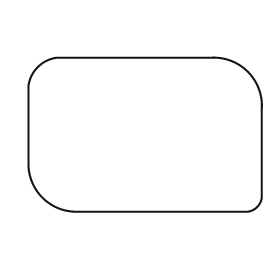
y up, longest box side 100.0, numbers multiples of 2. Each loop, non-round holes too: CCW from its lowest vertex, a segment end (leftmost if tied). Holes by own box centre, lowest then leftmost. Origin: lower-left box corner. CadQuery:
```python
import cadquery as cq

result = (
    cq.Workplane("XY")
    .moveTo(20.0, 0.0)
    .lineTo(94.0, 0.0)
    .threePointArc((98.0, 2.0), (100.0, 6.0))
    .lineTo(100.0, 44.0)
    .threePointArc((94.0, 60.0), (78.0, 66.0))
    .lineTo(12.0, 66.0)
    .threePointArc((4.0, 62.0), (0.0, 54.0))
    .lineTo(0.0, 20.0)
    .threePointArc((6.0, 6.0), (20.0, 0.0))
    .close()
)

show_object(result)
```